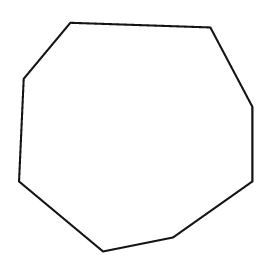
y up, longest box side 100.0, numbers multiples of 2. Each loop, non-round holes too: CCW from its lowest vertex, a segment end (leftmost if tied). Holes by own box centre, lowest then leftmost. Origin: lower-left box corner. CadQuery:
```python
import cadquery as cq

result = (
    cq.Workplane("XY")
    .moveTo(36.0, 0.0)
    .lineTo(66.0, 6.0)
    .lineTo(100.0, 30.0)
    .lineTo(100.0, 62.0)
    .lineTo(82.0, 96.0)
    .lineTo(22.0, 98.0)
    .lineTo(2.0, 74.0)
    .lineTo(0.0, 30.0)
    .close()
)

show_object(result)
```